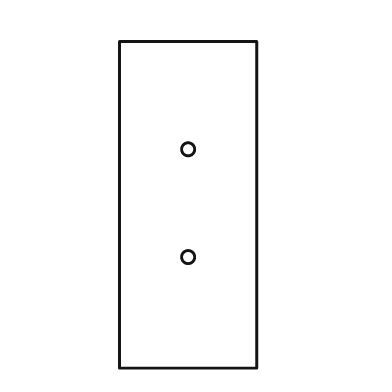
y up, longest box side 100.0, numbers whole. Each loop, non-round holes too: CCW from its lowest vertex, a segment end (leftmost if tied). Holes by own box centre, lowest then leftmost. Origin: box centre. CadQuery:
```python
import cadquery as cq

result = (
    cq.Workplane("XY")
    .moveTo(-21.0, -50.0)
    .lineTo(21.0, -50.0)
    .lineTo(21.0, 50.0)
    .lineTo(-21.0, 50.0)
    .close()
    .moveTo(0.0, -16.0)
    .circle(2.0)
    .moveTo(0.0, 17.0)
    .circle(2.0)
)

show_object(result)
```